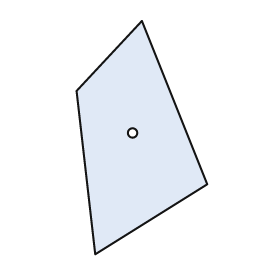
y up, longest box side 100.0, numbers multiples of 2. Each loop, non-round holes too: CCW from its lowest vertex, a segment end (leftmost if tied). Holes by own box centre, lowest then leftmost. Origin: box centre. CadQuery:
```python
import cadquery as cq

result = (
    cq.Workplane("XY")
    .moveTo(-20.0, -50.0)
    .lineTo(28.0, -20.0)
    .lineTo(0.0, 50.0)
    .lineTo(-28.0, 20.0)
    .close()
    .moveTo(-4.0, 2.0)
    .circle(2.0)
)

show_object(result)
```